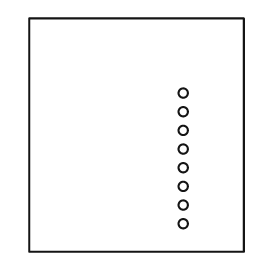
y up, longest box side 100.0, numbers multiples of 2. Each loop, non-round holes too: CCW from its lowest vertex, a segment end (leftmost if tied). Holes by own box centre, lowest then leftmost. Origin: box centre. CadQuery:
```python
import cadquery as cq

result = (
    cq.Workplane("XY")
    .moveTo(-46.0, -50.0)
    .lineTo(46.0, -50.0)
    .lineTo(46.0, 50.0)
    .lineTo(-46.0, 50.0)
    .close()
    .moveTo(20.0, -38.0)
    .circle(2.0)
    .moveTo(20.0, -30.0)
    .circle(2.0)
    .moveTo(20.0, -22.0)
    .circle(2.0)
    .moveTo(20.0, -14.0)
    .circle(2.0)
    .moveTo(20.0, -6.0)
    .circle(2.0)
    .moveTo(20.0, 2.0)
    .circle(2.0)
    .moveTo(20.0, 10.0)
    .circle(2.0)
    .moveTo(20.0, 18.0)
    .circle(2.0)
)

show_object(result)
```